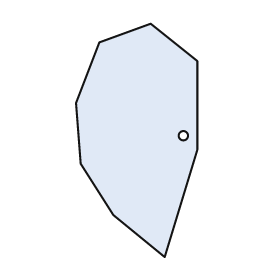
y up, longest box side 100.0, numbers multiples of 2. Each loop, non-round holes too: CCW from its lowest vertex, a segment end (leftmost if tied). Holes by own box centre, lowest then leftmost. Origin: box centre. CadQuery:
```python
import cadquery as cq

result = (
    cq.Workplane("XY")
    .moveTo(12.0, -50.0)
    .lineTo(26.0, -4.0)
    .lineTo(26.0, 34.0)
    .lineTo(6.0, 50.0)
    .lineTo(-16.0, 42.0)
    .lineTo(-26.0, 16.0)
    .lineTo(-24.0, -10.0)
    .lineTo(-10.0, -32.0)
    .close()
    .moveTo(20.0, 2.0)
    .circle(2.0)
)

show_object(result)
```